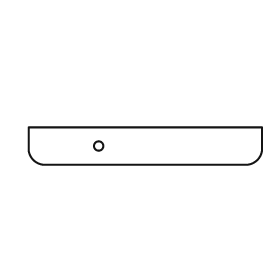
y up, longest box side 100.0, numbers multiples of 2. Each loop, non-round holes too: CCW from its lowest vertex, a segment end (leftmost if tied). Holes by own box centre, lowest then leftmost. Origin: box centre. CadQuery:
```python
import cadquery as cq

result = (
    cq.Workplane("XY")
    .moveTo(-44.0, -8.0)
    .lineTo(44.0, -8.0)
    .threePointArc((48.0, -6.0), (50.0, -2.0))
    .lineTo(50.0, 8.0)
    .lineTo(-50.0, 8.0)
    .lineTo(-50.0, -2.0)
    .threePointArc((-48.0, -6.0), (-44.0, -8.0))
    .close()
    .moveTo(-20.0, 0.0)
    .circle(2.0)
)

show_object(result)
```